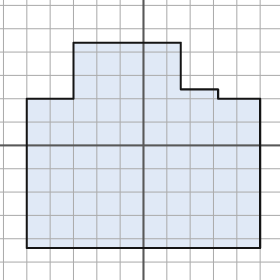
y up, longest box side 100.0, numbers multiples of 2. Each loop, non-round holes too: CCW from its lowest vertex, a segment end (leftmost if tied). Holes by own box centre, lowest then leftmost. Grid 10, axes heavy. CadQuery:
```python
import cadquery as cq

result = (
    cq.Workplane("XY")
    .moveTo(-50.0, -44.0)
    .lineTo(50.0, -44.0)
    .lineTo(50.0, 20.0)
    .lineTo(32.0, 20.0)
    .lineTo(32.0, 24.0)
    .lineTo(16.0, 24.0)
    .lineTo(16.0, 44.0)
    .lineTo(-30.0, 44.0)
    .lineTo(-30.0, 20.0)
    .lineTo(-50.0, 20.0)
    .close()
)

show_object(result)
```